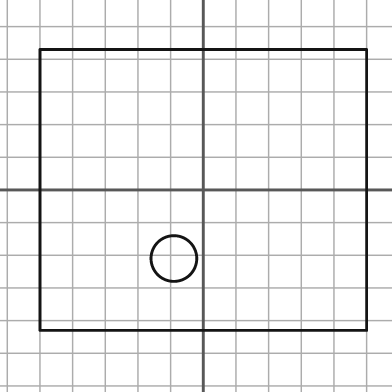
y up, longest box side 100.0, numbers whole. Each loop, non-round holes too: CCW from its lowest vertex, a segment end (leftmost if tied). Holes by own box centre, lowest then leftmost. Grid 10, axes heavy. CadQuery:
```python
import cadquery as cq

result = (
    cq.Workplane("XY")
    .moveTo(-50.0, -43.0)
    .lineTo(50.0, -43.0)
    .lineTo(50.0, 43.0)
    .lineTo(-50.0, 43.0)
    .close()
    .moveTo(-9.0, -21.0)
    .circle(7.0)
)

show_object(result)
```